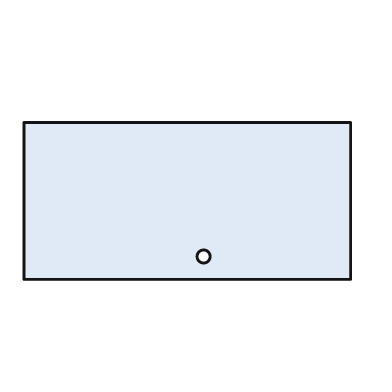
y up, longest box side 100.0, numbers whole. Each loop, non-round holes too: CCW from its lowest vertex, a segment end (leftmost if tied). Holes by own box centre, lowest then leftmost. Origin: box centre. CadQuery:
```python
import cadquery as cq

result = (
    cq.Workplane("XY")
    .moveTo(-50.0, -24.0)
    .lineTo(50.0, -24.0)
    .lineTo(50.0, 24.0)
    .lineTo(-50.0, 24.0)
    .close()
    .moveTo(5.0, -17.0)
    .circle(2.0)
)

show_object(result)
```